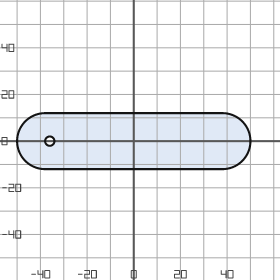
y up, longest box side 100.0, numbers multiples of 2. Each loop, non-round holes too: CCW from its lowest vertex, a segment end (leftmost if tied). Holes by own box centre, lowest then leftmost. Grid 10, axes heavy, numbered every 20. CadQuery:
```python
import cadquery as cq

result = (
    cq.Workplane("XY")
    .moveTo(-38.0, -12.0)
    .lineTo(38.0, -12.0)
    .threePointArc((50.0, 0.0), (38.0, 12.0))
    .lineTo(-38.0, 12.0)
    .threePointArc((-50.0, 0.0), (-38.0, -12.0))
    .close()
    .moveTo(-36.0, 0.0)
    .circle(2.0)
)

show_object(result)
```